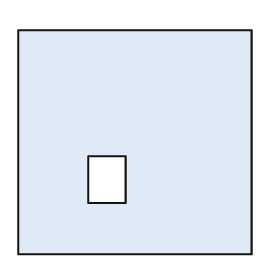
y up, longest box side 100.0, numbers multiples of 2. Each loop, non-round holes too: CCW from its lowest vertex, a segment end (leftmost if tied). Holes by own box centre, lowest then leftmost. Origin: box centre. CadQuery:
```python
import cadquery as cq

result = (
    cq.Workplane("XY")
    .moveTo(-50.0, -48.0)
    .lineTo(50.0, -48.0)
    .lineTo(50.0, 48.0)
    .lineTo(-50.0, 48.0)
    .close()
    .moveTo(-20.0, -26.0)
    .lineTo(-4.0, -26.0)
    .lineTo(-4.0, -6.0)
    .lineTo(-20.0, -6.0)
    .close()
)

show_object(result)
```